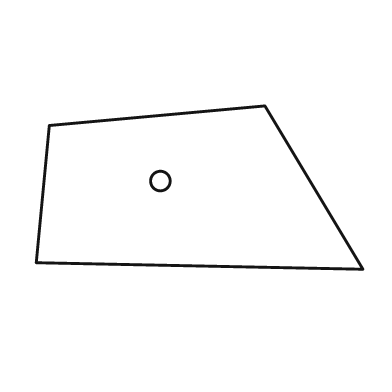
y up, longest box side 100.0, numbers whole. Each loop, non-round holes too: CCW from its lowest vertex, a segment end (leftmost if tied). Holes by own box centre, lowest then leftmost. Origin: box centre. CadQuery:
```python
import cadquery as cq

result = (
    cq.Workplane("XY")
    .moveTo(50.0, -25.0)
    .lineTo(20.0, 25.0)
    .lineTo(-46.0, 19.0)
    .lineTo(-50.0, -23.0)
    .close()
    .moveTo(-12.0, 2.0)
    .circle(3.0)
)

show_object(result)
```